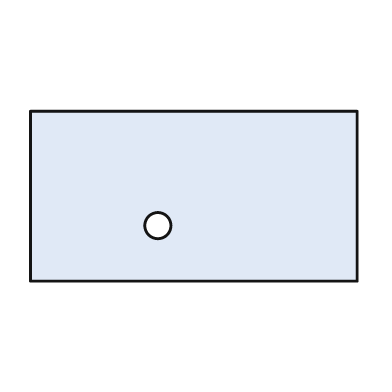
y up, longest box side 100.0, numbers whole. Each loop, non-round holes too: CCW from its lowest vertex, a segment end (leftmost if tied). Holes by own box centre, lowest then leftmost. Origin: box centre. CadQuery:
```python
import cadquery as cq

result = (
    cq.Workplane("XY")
    .moveTo(-50.0, -26.0)
    .lineTo(50.0, -26.0)
    .lineTo(50.0, 26.0)
    .lineTo(-50.0, 26.0)
    .close()
    .moveTo(-11.0, -9.0)
    .circle(4.0)
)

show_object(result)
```